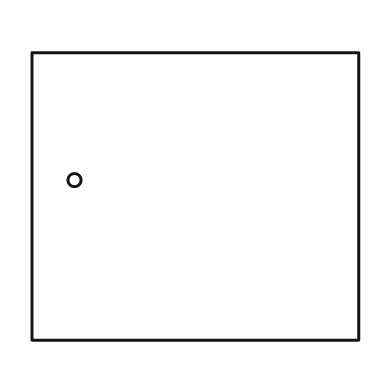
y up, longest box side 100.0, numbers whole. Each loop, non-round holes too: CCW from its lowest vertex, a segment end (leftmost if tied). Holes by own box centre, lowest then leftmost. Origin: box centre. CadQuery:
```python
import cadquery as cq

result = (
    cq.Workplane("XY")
    .moveTo(-50.0, -44.0)
    .lineTo(50.0, -44.0)
    .lineTo(50.0, 44.0)
    .lineTo(-50.0, 44.0)
    .close()
    .moveTo(-37.0, 5.0)
    .circle(2.0)
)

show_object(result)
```